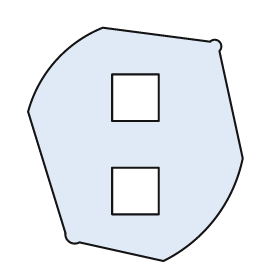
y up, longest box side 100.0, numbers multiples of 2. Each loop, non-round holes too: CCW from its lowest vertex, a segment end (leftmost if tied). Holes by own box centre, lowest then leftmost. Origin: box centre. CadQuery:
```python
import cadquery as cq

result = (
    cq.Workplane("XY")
    .moveTo(12.0, -50.0)
    .threePointArc((34.0, -32.0), (46.0, -6.0))
    .lineTo(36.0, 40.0)
    .threePointArc((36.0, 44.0), (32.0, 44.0))
    .lineTo(-14.0, 50.0)
    .threePointArc((-34.0, 36.0), (-46.0, 14.0))
    .lineTo(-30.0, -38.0)
    .threePointArc((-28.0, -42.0), (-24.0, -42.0))
    .close()
    .moveTo(-10.0, -30.0)
    .lineTo(10.0, -30.0)
    .lineTo(10.0, -10.0)
    .lineTo(-10.0, -10.0)
    .close()
    .moveTo(-10.0, 10.0)
    .lineTo(10.0, 10.0)
    .lineTo(10.0, 30.0)
    .lineTo(-10.0, 30.0)
    .close()
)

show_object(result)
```